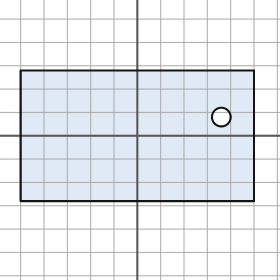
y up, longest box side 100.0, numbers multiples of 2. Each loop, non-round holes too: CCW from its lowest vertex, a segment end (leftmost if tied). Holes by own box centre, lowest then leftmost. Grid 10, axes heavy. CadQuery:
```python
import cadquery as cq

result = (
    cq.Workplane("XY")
    .moveTo(-50.0, -28.0)
    .lineTo(50.0, -28.0)
    .lineTo(50.0, 28.0)
    .lineTo(-50.0, 28.0)
    .close()
    .moveTo(36.0, 8.0)
    .circle(4.0)
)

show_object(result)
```